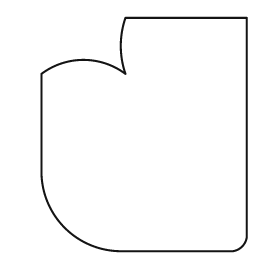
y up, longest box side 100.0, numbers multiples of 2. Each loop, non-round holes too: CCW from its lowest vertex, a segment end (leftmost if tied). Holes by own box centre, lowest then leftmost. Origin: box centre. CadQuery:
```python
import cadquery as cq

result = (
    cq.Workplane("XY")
    .moveTo(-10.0, -50.0)
    .lineTo(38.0, -50.0)
    .threePointArc((42.0, -48.0), (44.0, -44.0))
    .lineTo(44.0, 50.0)
    .lineTo(-8.0, 50.0)
    .threePointArc((-10.0, 38.0), (-8.0, 26.0))
    .threePointArc((-26.0, 32.0), (-44.0, 26.0))
    .lineTo(-44.0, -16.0)
    .threePointArc((-34.0, -40.0), (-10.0, -50.0))
    .close()
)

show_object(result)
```